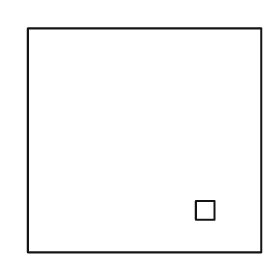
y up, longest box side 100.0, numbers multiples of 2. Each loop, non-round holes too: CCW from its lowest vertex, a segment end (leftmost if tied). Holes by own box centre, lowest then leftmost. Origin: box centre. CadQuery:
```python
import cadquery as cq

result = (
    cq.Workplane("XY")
    .moveTo(-50.0, -48.0)
    .lineTo(50.0, -48.0)
    .lineTo(50.0, 48.0)
    .lineTo(-50.0, 48.0)
    .close()
    .moveTo(22.0, -34.0)
    .lineTo(30.0, -34.0)
    .lineTo(30.0, -26.0)
    .lineTo(22.0, -26.0)
    .close()
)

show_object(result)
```